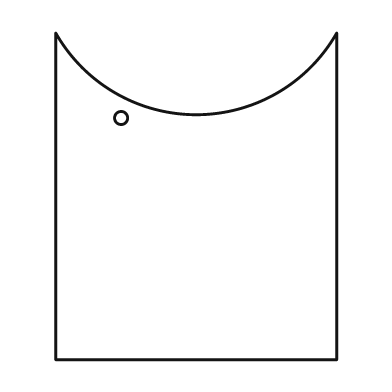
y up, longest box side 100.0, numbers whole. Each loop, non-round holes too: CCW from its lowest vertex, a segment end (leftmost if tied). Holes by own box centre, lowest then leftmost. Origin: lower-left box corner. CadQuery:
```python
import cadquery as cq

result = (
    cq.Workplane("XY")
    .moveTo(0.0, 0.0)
    .lineTo(86.0, 0.0)
    .lineTo(86.0, 100.0)
    .threePointArc((43.0, 75.0), (0.0, 100.0))
    .close()
    .moveTo(20.0, 74.0)
    .circle(2.0)
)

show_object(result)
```